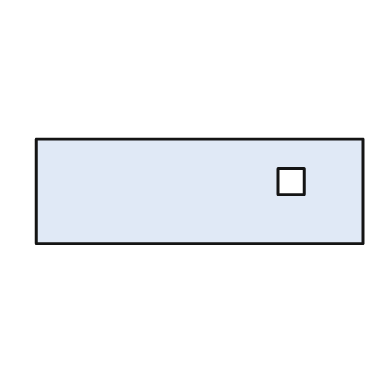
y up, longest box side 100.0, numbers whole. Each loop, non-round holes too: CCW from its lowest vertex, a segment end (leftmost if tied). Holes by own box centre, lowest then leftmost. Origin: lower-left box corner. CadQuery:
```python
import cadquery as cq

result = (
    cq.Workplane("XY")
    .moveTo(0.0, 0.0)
    .lineTo(100.0, 0.0)
    .lineTo(100.0, 32.0)
    .lineTo(0.0, 32.0)
    .close()
    .moveTo(74.0, 15.0)
    .lineTo(82.0, 15.0)
    .lineTo(82.0, 23.0)
    .lineTo(74.0, 23.0)
    .close()
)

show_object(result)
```